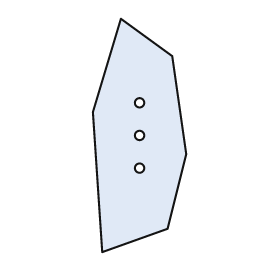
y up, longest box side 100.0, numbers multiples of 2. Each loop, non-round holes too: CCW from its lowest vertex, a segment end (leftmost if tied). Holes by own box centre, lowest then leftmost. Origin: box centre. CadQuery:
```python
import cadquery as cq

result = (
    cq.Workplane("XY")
    .moveTo(-16.0, -50.0)
    .lineTo(12.0, -40.0)
    .lineTo(20.0, -8.0)
    .lineTo(14.0, 34.0)
    .lineTo(-8.0, 50.0)
    .lineTo(-20.0, 10.0)
    .close()
    .moveTo(0.0, -14.0)
    .circle(2.0)
    .moveTo(0.0, 0.0)
    .circle(2.0)
    .moveTo(0.0, 14.0)
    .circle(2.0)
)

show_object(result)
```